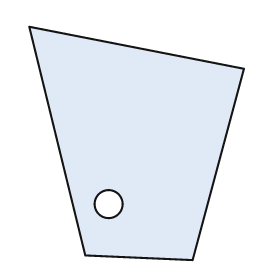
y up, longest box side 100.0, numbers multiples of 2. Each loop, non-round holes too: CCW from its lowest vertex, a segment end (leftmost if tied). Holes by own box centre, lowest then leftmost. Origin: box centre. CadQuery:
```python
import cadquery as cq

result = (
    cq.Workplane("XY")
    .moveTo(24.0, -50.0)
    .lineTo(46.0, 32.0)
    .lineTo(-46.0, 50.0)
    .lineTo(-22.0, -48.0)
    .close()
    .moveTo(-12.0, -26.0)
    .circle(6.0)
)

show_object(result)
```